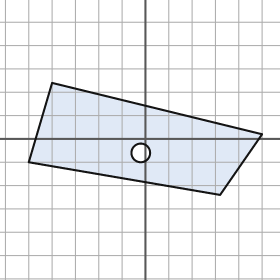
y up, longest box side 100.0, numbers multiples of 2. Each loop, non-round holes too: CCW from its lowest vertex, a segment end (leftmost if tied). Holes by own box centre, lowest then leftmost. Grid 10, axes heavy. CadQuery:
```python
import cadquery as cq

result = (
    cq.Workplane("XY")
    .moveTo(32.0, -24.0)
    .lineTo(50.0, 2.0)
    .lineTo(-40.0, 24.0)
    .lineTo(-50.0, -10.0)
    .close()
    .moveTo(-2.0, -6.0)
    .circle(4.0)
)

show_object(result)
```